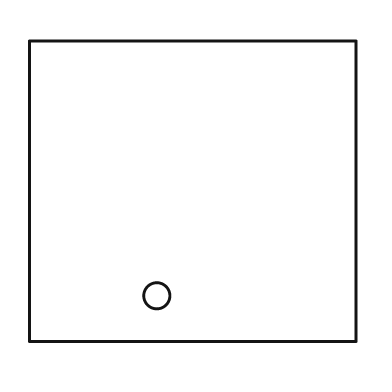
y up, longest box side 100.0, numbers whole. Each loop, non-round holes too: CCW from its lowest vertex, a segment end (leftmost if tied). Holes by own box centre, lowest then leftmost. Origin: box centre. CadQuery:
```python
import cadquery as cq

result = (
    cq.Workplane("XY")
    .moveTo(-50.0, -46.0)
    .lineTo(50.0, -46.0)
    .lineTo(50.0, 46.0)
    .lineTo(-50.0, 46.0)
    .close()
    .moveTo(-11.0, -32.0)
    .circle(4.0)
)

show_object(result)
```